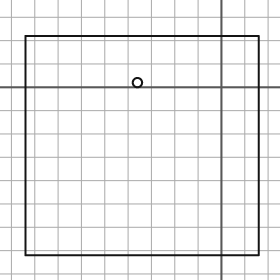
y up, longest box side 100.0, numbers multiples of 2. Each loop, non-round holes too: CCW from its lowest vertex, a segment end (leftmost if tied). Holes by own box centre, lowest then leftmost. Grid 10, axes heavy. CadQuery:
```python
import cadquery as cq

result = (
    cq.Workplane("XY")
    .moveTo(-84.0, -72.0)
    .lineTo(16.0, -72.0)
    .lineTo(16.0, 22.0)
    .lineTo(-84.0, 22.0)
    .close()
    .moveTo(-36.0, 2.0)
    .circle(2.0)
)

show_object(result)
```